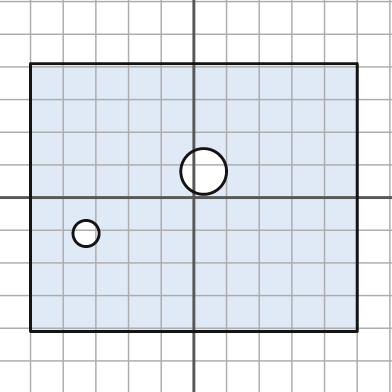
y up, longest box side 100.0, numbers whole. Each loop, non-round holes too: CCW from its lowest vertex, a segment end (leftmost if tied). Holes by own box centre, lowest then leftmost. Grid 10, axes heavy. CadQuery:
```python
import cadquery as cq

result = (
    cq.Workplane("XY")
    .moveTo(-50.0, -41.0)
    .lineTo(50.0, -41.0)
    .lineTo(50.0, 41.0)
    .lineTo(-50.0, 41.0)
    .close()
    .moveTo(-33.0, -11.0)
    .circle(4.0)
    .moveTo(3.0, 8.0)
    .circle(7.0)
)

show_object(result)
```